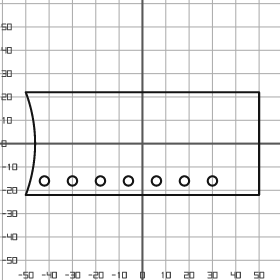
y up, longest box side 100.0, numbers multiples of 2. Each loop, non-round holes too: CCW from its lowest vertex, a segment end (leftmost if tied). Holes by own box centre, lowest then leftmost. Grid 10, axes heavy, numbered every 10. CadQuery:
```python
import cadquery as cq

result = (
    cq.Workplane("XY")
    .moveTo(-50.0, -22.0)
    .lineTo(50.0, -22.0)
    .lineTo(50.0, 22.0)
    .lineTo(-50.0, 22.0)
    .threePointArc((-46.0, 0.0), (-50.0, -22.0))
    .close()
    .moveTo(-42.0, -16.0)
    .circle(2.0)
    .moveTo(-30.0, -16.0)
    .circle(2.0)
    .moveTo(-18.0, -16.0)
    .circle(2.0)
    .moveTo(-6.0, -16.0)
    .circle(2.0)
    .moveTo(6.0, -16.0)
    .circle(2.0)
    .moveTo(18.0, -16.0)
    .circle(2.0)
    .moveTo(30.0, -16.0)
    .circle(2.0)
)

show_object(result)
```